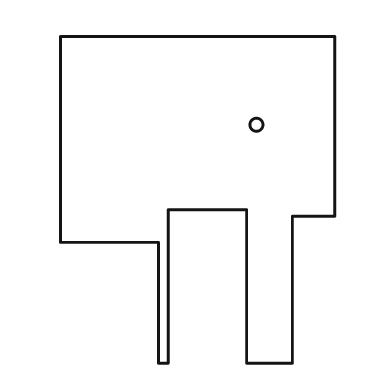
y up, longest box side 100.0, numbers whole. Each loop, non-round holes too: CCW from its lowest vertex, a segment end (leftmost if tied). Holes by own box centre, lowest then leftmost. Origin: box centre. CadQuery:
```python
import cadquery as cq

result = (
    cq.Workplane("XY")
    .moveTo(-12.0, -50.0)
    .lineTo(-9.0, -50.0)
    .lineTo(-9.0, -3.0)
    .lineTo(15.0, -3.0)
    .lineTo(15.0, -50.0)
    .lineTo(29.0, -50.0)
    .lineTo(29.0, -5.0)
    .lineTo(42.0, -5.0)
    .lineTo(42.0, 50.0)
    .lineTo(-42.0, 50.0)
    .lineTo(-42.0, -13.0)
    .lineTo(-12.0, -13.0)
    .close()
    .moveTo(18.0, 23.0)
    .circle(2.0)
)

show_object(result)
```